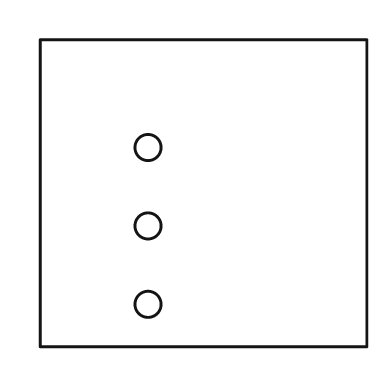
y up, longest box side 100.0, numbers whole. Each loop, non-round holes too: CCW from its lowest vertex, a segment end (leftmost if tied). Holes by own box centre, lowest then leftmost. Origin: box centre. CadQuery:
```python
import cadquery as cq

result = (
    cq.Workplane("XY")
    .moveTo(-50.0, -47.0)
    .lineTo(50.0, -47.0)
    .lineTo(50.0, 47.0)
    .lineTo(-50.0, 47.0)
    .close()
    .moveTo(-17.0, -34.0)
    .circle(4.0)
    .moveTo(-17.0, -10.0)
    .circle(4.0)
    .moveTo(-17.0, 14.0)
    .circle(4.0)
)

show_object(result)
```